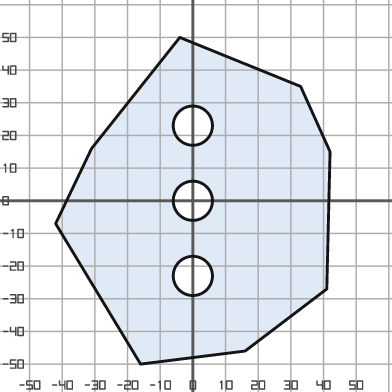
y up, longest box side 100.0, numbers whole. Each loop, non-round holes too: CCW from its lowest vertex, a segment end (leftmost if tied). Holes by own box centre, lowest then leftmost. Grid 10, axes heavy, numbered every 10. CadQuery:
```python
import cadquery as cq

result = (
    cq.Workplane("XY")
    .moveTo(-16.0, -50.0)
    .lineTo(16.0, -46.0)
    .lineTo(41.0, -27.0)
    .lineTo(42.0, 15.0)
    .lineTo(33.0, 35.0)
    .lineTo(-4.0, 50.0)
    .lineTo(-31.0, 16.0)
    .lineTo(-42.0, -7.0)
    .close()
    .moveTo(0.0, -23.0)
    .circle(6.0)
    .moveTo(0.0, 0.0)
    .circle(6.0)
    .moveTo(0.0, 23.0)
    .circle(6.0)
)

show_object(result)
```